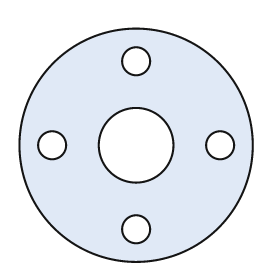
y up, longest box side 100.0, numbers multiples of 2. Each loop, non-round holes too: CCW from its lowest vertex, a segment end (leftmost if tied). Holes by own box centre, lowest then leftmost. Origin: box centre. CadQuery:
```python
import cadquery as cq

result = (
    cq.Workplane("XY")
    .moveTo(0.0, 0.0)
    .circle(50.0)
    .moveTo(0.0, -36.0)
    .circle(6.0)
    .moveTo(-36.0, 0.0)
    .circle(6.0)
    .moveTo(0.0, 0.0)
    .circle(16.0)
    .moveTo(36.0, 0.0)
    .circle(6.0)
    .moveTo(0.0, 36.0)
    .circle(6.0)
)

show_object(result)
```